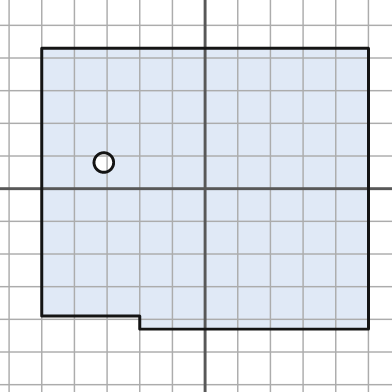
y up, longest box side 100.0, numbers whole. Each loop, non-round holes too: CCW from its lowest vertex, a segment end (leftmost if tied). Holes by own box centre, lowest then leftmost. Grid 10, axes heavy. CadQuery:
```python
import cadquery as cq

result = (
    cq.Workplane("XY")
    .moveTo(-20.0, -43.0)
    .lineTo(50.0, -43.0)
    .lineTo(50.0, 43.0)
    .lineTo(-50.0, 43.0)
    .lineTo(-50.0, -39.0)
    .lineTo(-20.0, -39.0)
    .close()
    .moveTo(-31.0, 8.0)
    .circle(3.0)
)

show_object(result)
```